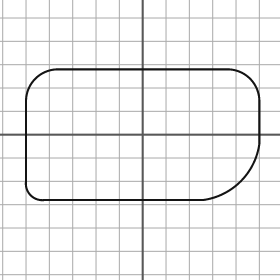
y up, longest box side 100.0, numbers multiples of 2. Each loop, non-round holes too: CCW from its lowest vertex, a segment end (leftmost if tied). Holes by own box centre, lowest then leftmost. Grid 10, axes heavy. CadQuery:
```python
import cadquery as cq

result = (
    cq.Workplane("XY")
    .moveTo(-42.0, -28.0)
    .lineTo(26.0, -28.0)
    .threePointArc((42.0, -20.0), (50.0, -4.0))
    .lineTo(50.0, 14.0)
    .threePointArc((46.0, 24.0), (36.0, 28.0))
    .lineTo(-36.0, 28.0)
    .threePointArc((-46.0, 24.0), (-50.0, 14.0))
    .lineTo(-50.0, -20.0)
    .threePointArc((-48.0, -26.0), (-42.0, -28.0))
    .close()
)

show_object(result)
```